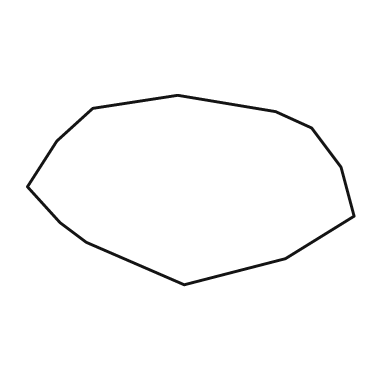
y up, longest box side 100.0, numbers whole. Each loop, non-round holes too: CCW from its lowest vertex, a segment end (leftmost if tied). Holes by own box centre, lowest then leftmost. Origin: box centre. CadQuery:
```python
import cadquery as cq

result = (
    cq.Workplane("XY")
    .moveTo(-2.0, -29.0)
    .lineTo(29.0, -21.0)
    .lineTo(50.0, -8.0)
    .lineTo(46.0, 7.0)
    .lineTo(37.0, 19.0)
    .lineTo(26.0, 24.0)
    .lineTo(-4.0, 29.0)
    .lineTo(-30.0, 25.0)
    .lineTo(-41.0, 15.0)
    .lineTo(-50.0, 1.0)
    .lineTo(-40.0, -10.0)
    .lineTo(-32.0, -16.0)
    .close()
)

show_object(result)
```